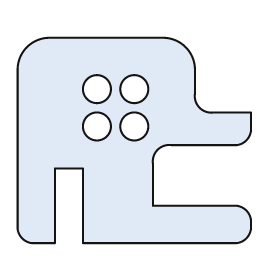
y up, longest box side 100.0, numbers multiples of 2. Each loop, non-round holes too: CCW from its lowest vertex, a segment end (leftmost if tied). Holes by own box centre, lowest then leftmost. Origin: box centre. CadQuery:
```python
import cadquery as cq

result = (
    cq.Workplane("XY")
    .moveTo(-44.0, -44.0)
    .lineTo(-34.0, -44.0)
    .lineTo(-34.0, -12.0)
    .lineTo(-22.0, -12.0)
    .lineTo(-22.0, -44.0)
    .lineTo(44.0, -44.0)
    .threePointArc((48.0, -42.0), (50.0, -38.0))
    .lineTo(50.0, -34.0)
    .threePointArc((48.0, -30.0), (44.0, -28.0))
    .lineTo(8.0, -28.0)
    .lineTo(8.0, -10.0)
    .threePointArc((10.0, -4.0), (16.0, -2.0))
    .lineTo(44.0, -2.0)
    .threePointArc((48.0, 0.0), (50.0, 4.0))
    .lineTo(50.0, 12.0)
    .lineTo(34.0, 12.0)
    .threePointArc((28.0, 14.0), (26.0, 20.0))
    .lineTo(26.0, 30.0)
    .threePointArc((22.0, 40.0), (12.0, 44.0))
    .lineTo(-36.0, 44.0)
    .threePointArc((-46.0, 40.0), (-50.0, 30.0))
    .lineTo(-50.0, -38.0)
    .threePointArc((-48.0, -42.0), (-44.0, -44.0))
    .close()
    .moveTo(-16.0, 6.0)
    .circle(6.0)
    .moveTo(0.0, 6.0)
    .circle(6.0)
    .moveTo(-16.0, 22.0)
    .circle(6.0)
    .moveTo(0.0, 22.0)
    .circle(6.0)
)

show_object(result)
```